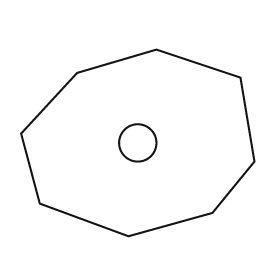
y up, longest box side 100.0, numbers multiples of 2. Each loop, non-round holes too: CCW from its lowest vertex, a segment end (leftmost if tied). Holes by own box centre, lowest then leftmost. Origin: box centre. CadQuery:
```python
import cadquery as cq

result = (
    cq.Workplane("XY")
    .moveTo(-4.0, -40.0)
    .lineTo(32.0, -30.0)
    .lineTo(50.0, -8.0)
    .lineTo(44.0, 28.0)
    .lineTo(8.0, 40.0)
    .lineTo(-26.0, 30.0)
    .lineTo(-50.0, 4.0)
    .lineTo(-42.0, -26.0)
    .close()
    .moveTo(0.0, 0.0)
    .circle(8.0)
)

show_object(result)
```